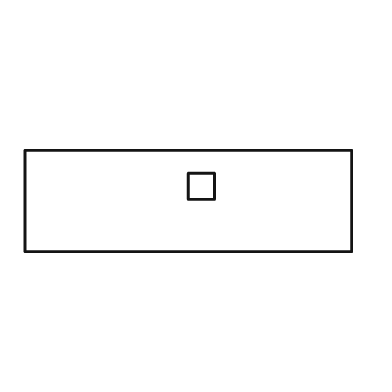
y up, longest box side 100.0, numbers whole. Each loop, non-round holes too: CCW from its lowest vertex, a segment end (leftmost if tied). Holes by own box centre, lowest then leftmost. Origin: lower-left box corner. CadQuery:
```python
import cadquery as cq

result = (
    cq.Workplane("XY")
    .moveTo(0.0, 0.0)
    .lineTo(100.0, 0.0)
    .lineTo(100.0, 31.0)
    .lineTo(0.0, 31.0)
    .close()
    .moveTo(50.0, 16.0)
    .lineTo(58.0, 16.0)
    .lineTo(58.0, 24.0)
    .lineTo(50.0, 24.0)
    .close()
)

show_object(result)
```